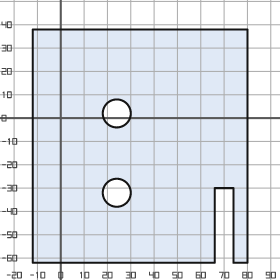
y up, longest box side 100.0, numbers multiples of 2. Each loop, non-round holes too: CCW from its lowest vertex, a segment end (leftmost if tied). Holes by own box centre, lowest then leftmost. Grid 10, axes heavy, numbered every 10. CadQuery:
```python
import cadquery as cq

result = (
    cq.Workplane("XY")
    .moveTo(-12.0, -62.0)
    .lineTo(66.0, -62.0)
    .lineTo(66.0, -30.0)
    .lineTo(74.0, -30.0)
    .lineTo(74.0, -62.0)
    .lineTo(80.0, -62.0)
    .lineTo(80.0, 38.0)
    .lineTo(-12.0, 38.0)
    .close()
    .moveTo(24.0, -32.0)
    .circle(6.0)
    .moveTo(24.0, 2.0)
    .circle(6.0)
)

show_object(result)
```